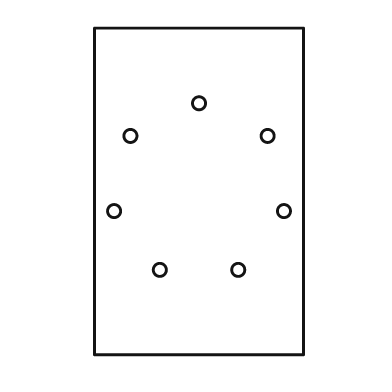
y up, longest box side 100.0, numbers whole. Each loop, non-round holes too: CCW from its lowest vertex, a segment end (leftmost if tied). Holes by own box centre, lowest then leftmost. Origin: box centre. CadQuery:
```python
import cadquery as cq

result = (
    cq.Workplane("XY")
    .moveTo(-32.0, -50.0)
    .lineTo(32.0, -50.0)
    .lineTo(32.0, 50.0)
    .lineTo(-32.0, 50.0)
    .close()
    .moveTo(-12.0, -24.0)
    .circle(2.0)
    .moveTo(12.0, -24.0)
    .circle(2.0)
    .moveTo(-26.0, -6.0)
    .circle(2.0)
    .moveTo(26.0, -6.0)
    .circle(2.0)
    .moveTo(-21.0, 17.0)
    .circle(2.0)
    .moveTo(21.0, 17.0)
    .circle(2.0)
    .moveTo(0.0, 27.0)
    .circle(2.0)
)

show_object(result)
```